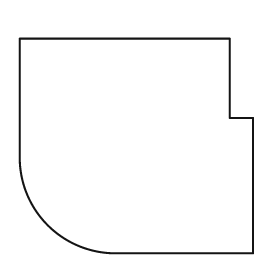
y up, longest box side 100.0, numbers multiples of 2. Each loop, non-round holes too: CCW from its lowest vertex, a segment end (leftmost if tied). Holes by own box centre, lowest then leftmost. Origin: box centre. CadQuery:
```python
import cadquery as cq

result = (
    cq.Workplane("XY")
    .moveTo(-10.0, -46.0)
    .lineTo(50.0, -46.0)
    .lineTo(50.0, 12.0)
    .lineTo(40.0, 12.0)
    .lineTo(40.0, 46.0)
    .lineTo(-50.0, 46.0)
    .lineTo(-50.0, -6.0)
    .threePointArc((-38.0, -34.0), (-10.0, -46.0))
    .close()
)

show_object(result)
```